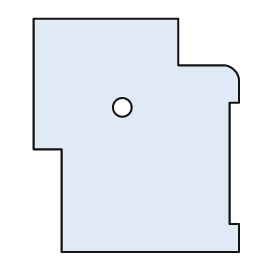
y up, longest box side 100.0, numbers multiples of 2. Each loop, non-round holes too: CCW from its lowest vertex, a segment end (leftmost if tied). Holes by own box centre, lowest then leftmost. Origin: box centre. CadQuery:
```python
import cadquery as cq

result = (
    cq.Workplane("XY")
    .moveTo(-32.0, -50.0)
    .lineTo(44.0, -50.0)
    .lineTo(44.0, -38.0)
    .lineTo(40.0, -38.0)
    .lineTo(40.0, 14.0)
    .lineTo(44.0, 14.0)
    .lineTo(44.0, 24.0)
    .threePointArc((42.0, 28.0), (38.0, 30.0))
    .lineTo(18.0, 30.0)
    .lineTo(18.0, 50.0)
    .lineTo(-44.0, 50.0)
    .lineTo(-44.0, -6.0)
    .lineTo(-32.0, -6.0)
    .close()
    .moveTo(-6.0, 12.0)
    .circle(4.0)
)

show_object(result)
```